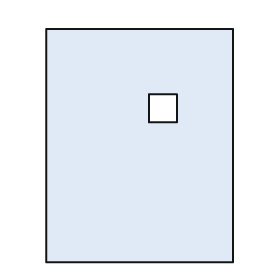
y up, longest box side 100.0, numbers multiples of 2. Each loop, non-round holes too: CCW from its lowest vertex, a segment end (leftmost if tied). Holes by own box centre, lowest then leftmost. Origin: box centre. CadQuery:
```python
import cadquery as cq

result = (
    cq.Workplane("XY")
    .moveTo(-40.0, -50.0)
    .lineTo(40.0, -50.0)
    .lineTo(40.0, 50.0)
    .lineTo(-40.0, 50.0)
    .close()
    .moveTo(4.0, 10.0)
    .lineTo(16.0, 10.0)
    .lineTo(16.0, 22.0)
    .lineTo(4.0, 22.0)
    .close()
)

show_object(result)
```